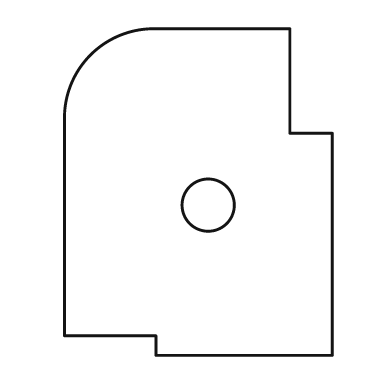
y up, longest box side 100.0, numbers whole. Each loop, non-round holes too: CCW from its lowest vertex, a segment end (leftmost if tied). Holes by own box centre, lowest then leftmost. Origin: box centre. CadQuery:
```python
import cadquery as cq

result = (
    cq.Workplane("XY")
    .moveTo(-13.0, -50.0)
    .lineTo(41.0, -50.0)
    .lineTo(41.0, 18.0)
    .lineTo(28.0, 18.0)
    .lineTo(28.0, 50.0)
    .lineTo(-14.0, 50.0)
    .threePointArc((-33.0, 42.0), (-41.0, 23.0))
    .lineTo(-41.0, -44.0)
    .lineTo(-13.0, -44.0)
    .close()
    .moveTo(3.0, -4.0)
    .circle(8.0)
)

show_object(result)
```